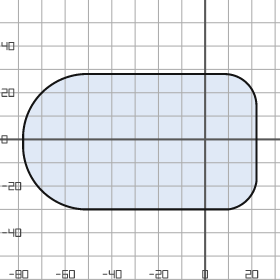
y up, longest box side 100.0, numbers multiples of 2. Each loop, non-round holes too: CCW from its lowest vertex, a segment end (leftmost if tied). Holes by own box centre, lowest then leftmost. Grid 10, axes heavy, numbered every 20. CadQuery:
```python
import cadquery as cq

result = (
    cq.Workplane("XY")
    .moveTo(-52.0, -30.0)
    .lineTo(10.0, -30.0)
    .threePointArc((18.0, -26.0), (22.0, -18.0))
    .lineTo(22.0, 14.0)
    .threePointArc((18.0, 24.0), (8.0, 28.0))
    .lineTo(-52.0, 28.0)
    .threePointArc((-70.0, 20.0), (-78.0, 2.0))
    .lineTo(-78.0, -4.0)
    .threePointArc((-70.0, -22.0), (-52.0, -30.0))
    .close()
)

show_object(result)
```